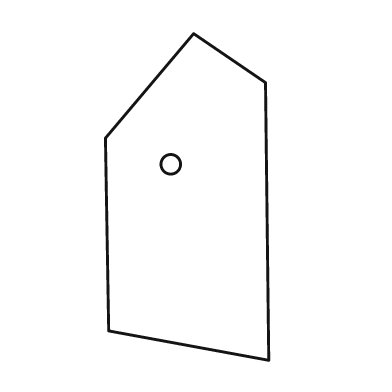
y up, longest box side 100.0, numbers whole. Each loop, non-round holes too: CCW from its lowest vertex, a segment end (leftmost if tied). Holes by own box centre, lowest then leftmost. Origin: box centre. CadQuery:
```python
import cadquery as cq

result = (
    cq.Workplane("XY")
    .moveTo(25.0, -50.0)
    .lineTo(24.0, 35.0)
    .lineTo(2.0, 50.0)
    .lineTo(-25.0, 18.0)
    .lineTo(-24.0, -41.0)
    .close()
    .moveTo(-5.0, 10.0)
    .circle(3.0)
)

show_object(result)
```